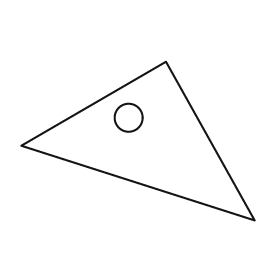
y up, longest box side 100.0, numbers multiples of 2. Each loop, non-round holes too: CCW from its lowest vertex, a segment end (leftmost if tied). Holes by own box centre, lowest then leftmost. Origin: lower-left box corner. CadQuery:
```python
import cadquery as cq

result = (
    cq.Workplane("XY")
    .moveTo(100.0, 0.0)
    .lineTo(62.0, 68.0)
    .lineTo(0.0, 32.0)
    .close()
    .moveTo(46.0, 44.0)
    .circle(6.0)
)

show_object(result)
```